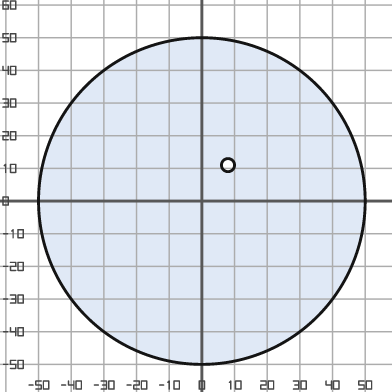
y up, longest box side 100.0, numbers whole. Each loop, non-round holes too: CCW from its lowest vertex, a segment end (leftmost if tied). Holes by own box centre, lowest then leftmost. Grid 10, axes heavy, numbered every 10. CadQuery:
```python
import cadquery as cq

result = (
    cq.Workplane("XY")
    .moveTo(0.0, 0.0)
    .circle(50.0)
    .moveTo(8.0, 11.0)
    .circle(2.0)
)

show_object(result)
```